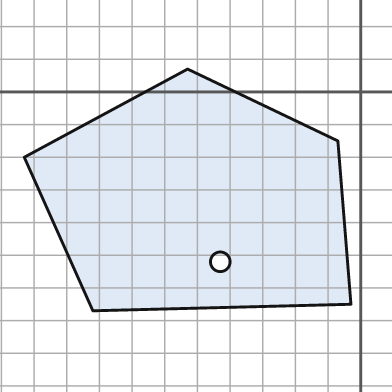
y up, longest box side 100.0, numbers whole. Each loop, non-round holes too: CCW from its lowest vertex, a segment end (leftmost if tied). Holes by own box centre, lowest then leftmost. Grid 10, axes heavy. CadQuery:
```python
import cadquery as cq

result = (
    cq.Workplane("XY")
    .moveTo(-82.0, -67.0)
    .lineTo(-3.0, -65.0)
    .lineTo(-7.0, -15.0)
    .lineTo(-53.0, 7.0)
    .lineTo(-103.0, -20.0)
    .close()
    .moveTo(-43.0, -52.0)
    .circle(3.0)
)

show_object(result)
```